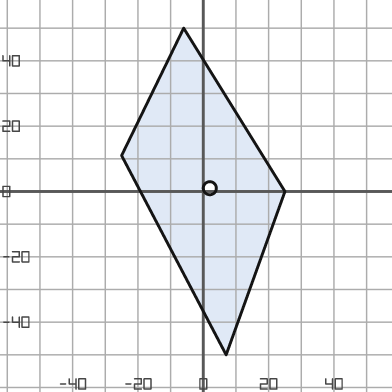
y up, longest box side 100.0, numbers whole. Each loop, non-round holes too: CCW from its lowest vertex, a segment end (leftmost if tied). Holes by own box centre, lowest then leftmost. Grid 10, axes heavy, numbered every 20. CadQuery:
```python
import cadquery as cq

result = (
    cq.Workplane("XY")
    .moveTo(7.0, -50.0)
    .lineTo(25.0, 0.0)
    .lineTo(-6.0, 50.0)
    .lineTo(-25.0, 11.0)
    .close()
    .moveTo(2.0, 1.0)
    .circle(2.0)
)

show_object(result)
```